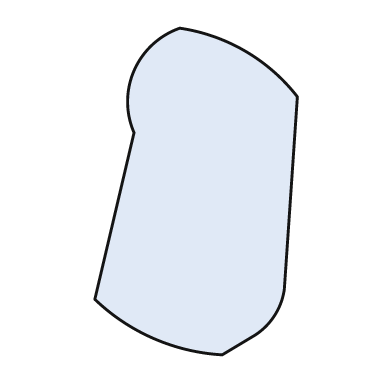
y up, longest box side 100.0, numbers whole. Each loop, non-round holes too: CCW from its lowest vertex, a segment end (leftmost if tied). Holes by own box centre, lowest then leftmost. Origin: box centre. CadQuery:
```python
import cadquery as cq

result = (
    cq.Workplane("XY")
    .moveTo(8.0, -50.0)
    .lineTo(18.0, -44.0)
    .threePointArc((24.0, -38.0), (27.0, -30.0))
    .lineTo(31.0, 29.0)
    .threePointArc((15.0, 43.0), (-5.0, 50.0))
    .threePointArc((-19.0, 37.0), (-19.0, 18.0))
    .lineTo(-31.0, -33.0)
    .threePointArc((-13.0, -45.0), (8.0, -50.0))
    .close()
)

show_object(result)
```